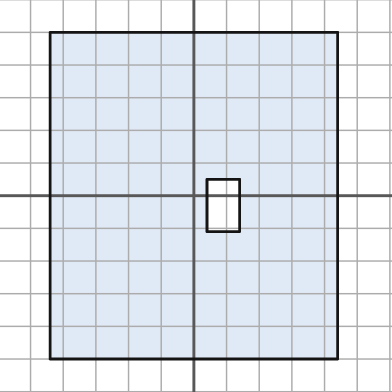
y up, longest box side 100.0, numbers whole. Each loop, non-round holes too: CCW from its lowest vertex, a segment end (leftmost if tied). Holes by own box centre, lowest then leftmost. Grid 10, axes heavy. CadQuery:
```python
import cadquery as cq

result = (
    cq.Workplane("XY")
    .moveTo(-44.0, -50.0)
    .lineTo(44.0, -50.0)
    .lineTo(44.0, 50.0)
    .lineTo(-44.0, 50.0)
    .close()
    .moveTo(4.0, -11.0)
    .lineTo(14.0, -11.0)
    .lineTo(14.0, 5.0)
    .lineTo(4.0, 5.0)
    .close()
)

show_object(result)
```